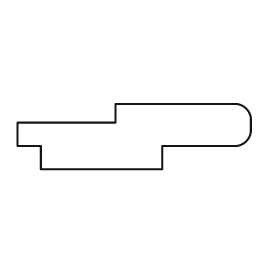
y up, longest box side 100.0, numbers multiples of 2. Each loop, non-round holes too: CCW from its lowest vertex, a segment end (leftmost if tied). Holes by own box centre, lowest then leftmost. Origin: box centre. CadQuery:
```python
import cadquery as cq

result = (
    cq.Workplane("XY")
    .moveTo(-40.0, -14.0)
    .lineTo(12.0, -14.0)
    .lineTo(12.0, -4.0)
    .lineTo(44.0, -4.0)
    .threePointArc((48.0, -2.0), (50.0, 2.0))
    .lineTo(50.0, 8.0)
    .threePointArc((48.0, 12.0), (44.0, 14.0))
    .lineTo(-8.0, 14.0)
    .lineTo(-8.0, 6.0)
    .lineTo(-50.0, 6.0)
    .lineTo(-50.0, -4.0)
    .lineTo(-40.0, -4.0)
    .close()
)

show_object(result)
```